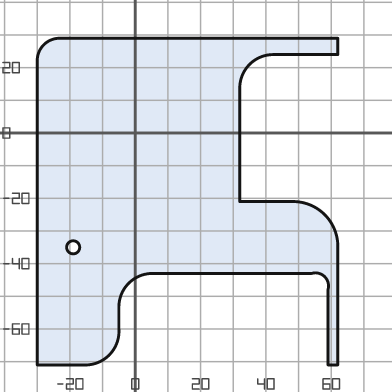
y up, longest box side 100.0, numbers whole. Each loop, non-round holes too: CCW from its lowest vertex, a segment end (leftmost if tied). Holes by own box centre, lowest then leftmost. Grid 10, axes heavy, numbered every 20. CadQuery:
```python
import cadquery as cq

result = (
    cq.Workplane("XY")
    .moveTo(-30.0, -71.0)
    .lineTo(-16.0, -71.0)
    .threePointArc((-8.0, -68.0), (-5.0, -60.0))
    .lineTo(-5.0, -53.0)
    .threePointArc((-2.0, -46.0), (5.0, -43.0))
    .lineTo(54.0, -43.0)
    .threePointArc((58.0, -44.0), (59.0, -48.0))
    .lineTo(59.0, -71.0)
    .lineTo(62.0, -71.0)
    .lineTo(62.0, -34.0)
    .threePointArc((58.0, -25.0), (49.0, -21.0))
    .lineTo(32.0, -21.0)
    .lineTo(32.0, 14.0)
    .threePointArc((35.0, 21.0), (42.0, 24.0))
    .lineTo(62.0, 24.0)
    .lineTo(62.0, 29.0)
    .lineTo(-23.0, 29.0)
    .threePointArc((-28.0, 27.0), (-30.0, 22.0))
    .close()
    .moveTo(-19.0, -35.0)
    .circle(2.0)
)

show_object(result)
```